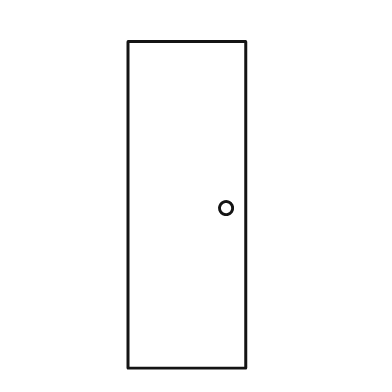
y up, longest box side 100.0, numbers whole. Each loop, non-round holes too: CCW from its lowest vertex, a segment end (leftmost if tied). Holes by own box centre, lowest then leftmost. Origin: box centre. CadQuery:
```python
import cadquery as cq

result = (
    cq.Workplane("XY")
    .moveTo(-18.0, -50.0)
    .lineTo(18.0, -50.0)
    .lineTo(18.0, 50.0)
    .lineTo(-18.0, 50.0)
    .close()
    .moveTo(12.0, -1.0)
    .circle(2.0)
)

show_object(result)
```